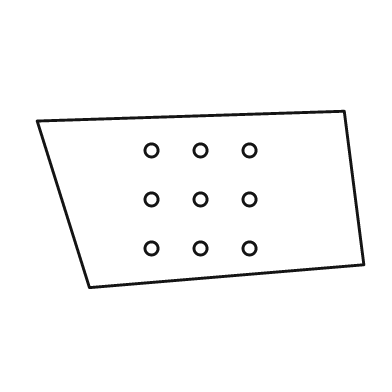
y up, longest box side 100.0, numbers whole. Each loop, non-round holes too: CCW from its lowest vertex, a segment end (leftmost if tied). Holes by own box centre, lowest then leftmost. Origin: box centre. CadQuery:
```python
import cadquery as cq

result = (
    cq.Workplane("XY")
    .moveTo(-34.0, -27.0)
    .lineTo(50.0, -20.0)
    .lineTo(44.0, 27.0)
    .lineTo(-50.0, 24.0)
    .close()
    .moveTo(-15.0, -15.0)
    .circle(2.0)
    .moveTo(0.0, -15.0)
    .circle(2.0)
    .moveTo(15.0, -15.0)
    .circle(2.0)
    .moveTo(-15.0, 0.0)
    .circle(2.0)
    .moveTo(0.0, 0.0)
    .circle(2.0)
    .moveTo(15.0, 0.0)
    .circle(2.0)
    .moveTo(-15.0, 15.0)
    .circle(2.0)
    .moveTo(0.0, 15.0)
    .circle(2.0)
    .moveTo(15.0, 15.0)
    .circle(2.0)
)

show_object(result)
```